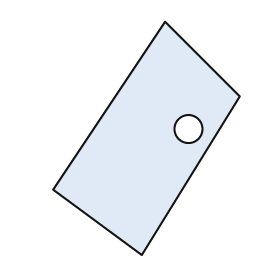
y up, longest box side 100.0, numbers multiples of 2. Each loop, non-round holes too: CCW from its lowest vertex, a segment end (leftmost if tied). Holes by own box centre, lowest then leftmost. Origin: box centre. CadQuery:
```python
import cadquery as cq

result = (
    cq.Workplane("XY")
    .moveTo(-2.0, -50.0)
    .lineTo(40.0, 18.0)
    .lineTo(8.0, 50.0)
    .lineTo(-40.0, -22.0)
    .close()
    .moveTo(18.0, 4.0)
    .circle(6.0)
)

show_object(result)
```